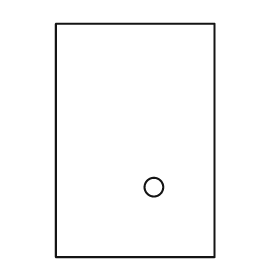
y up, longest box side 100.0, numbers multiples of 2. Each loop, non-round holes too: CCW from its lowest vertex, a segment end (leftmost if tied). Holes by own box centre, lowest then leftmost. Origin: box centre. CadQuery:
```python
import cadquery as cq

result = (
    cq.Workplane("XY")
    .moveTo(-34.0, -50.0)
    .lineTo(34.0, -50.0)
    .lineTo(34.0, 50.0)
    .lineTo(-34.0, 50.0)
    .close()
    .moveTo(8.0, -20.0)
    .circle(4.0)
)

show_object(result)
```